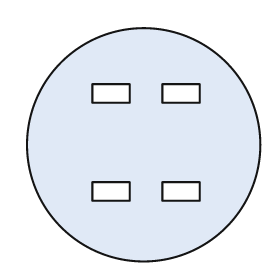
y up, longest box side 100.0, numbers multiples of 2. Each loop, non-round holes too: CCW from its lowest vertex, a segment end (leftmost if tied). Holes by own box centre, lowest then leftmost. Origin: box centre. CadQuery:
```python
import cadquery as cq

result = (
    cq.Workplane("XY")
    .moveTo(0.0, 0.0)
    .circle(50.0)
    .moveTo(-22.0, -24.0)
    .lineTo(-6.0, -24.0)
    .lineTo(-6.0, -16.0)
    .lineTo(-22.0, -16.0)
    .close()
    .moveTo(8.0, -24.0)
    .lineTo(24.0, -24.0)
    .lineTo(24.0, -16.0)
    .lineTo(8.0, -16.0)
    .close()
    .moveTo(-22.0, 18.0)
    .lineTo(-6.0, 18.0)
    .lineTo(-6.0, 26.0)
    .lineTo(-22.0, 26.0)
    .close()
    .moveTo(8.0, 18.0)
    .lineTo(24.0, 18.0)
    .lineTo(24.0, 26.0)
    .lineTo(8.0, 26.0)
    .close()
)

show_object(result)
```